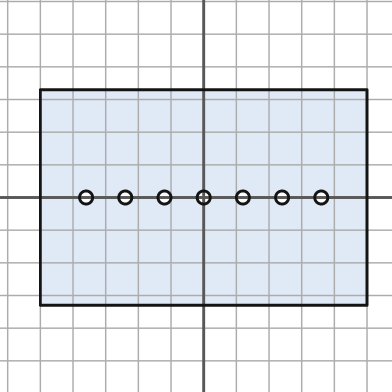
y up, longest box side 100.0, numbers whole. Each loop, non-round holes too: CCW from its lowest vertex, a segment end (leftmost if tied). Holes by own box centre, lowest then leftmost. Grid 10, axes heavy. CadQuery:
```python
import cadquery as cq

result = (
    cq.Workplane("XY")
    .moveTo(-50.0, -33.0)
    .lineTo(50.0, -33.0)
    .lineTo(50.0, 33.0)
    .lineTo(-50.0, 33.0)
    .close()
    .moveTo(-36.0, 0.0)
    .circle(2.0)
    .moveTo(-24.0, 0.0)
    .circle(2.0)
    .moveTo(-12.0, 0.0)
    .circle(2.0)
    .moveTo(0.0, 0.0)
    .circle(2.0)
    .moveTo(12.0, 0.0)
    .circle(2.0)
    .moveTo(24.0, 0.0)
    .circle(2.0)
    .moveTo(36.0, 0.0)
    .circle(2.0)
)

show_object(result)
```